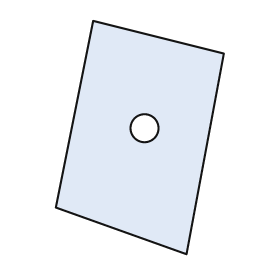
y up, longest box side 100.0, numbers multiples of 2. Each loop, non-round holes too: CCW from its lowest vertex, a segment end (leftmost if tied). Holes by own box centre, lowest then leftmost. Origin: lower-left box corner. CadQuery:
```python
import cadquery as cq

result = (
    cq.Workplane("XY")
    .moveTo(56.0, 0.0)
    .lineTo(72.0, 86.0)
    .lineTo(16.0, 100.0)
    .lineTo(0.0, 20.0)
    .close()
    .moveTo(38.0, 54.0)
    .circle(6.0)
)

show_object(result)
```